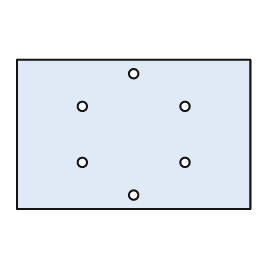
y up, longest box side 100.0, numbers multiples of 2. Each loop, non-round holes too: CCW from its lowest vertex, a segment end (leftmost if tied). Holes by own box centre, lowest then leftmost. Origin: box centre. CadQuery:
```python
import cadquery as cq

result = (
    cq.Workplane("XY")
    .moveTo(-50.0, -32.0)
    .lineTo(50.0, -32.0)
    .lineTo(50.0, 32.0)
    .lineTo(-50.0, 32.0)
    .close()
    .moveTo(0.0, -26.0)
    .circle(2.0)
    .moveTo(-22.0, -12.0)
    .circle(2.0)
    .moveTo(22.0, -12.0)
    .circle(2.0)
    .moveTo(-22.0, 12.0)
    .circle(2.0)
    .moveTo(22.0, 12.0)
    .circle(2.0)
    .moveTo(0.0, 26.0)
    .circle(2.0)
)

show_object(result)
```